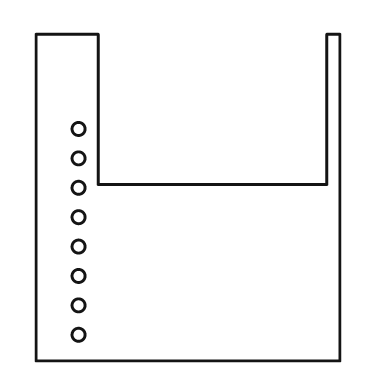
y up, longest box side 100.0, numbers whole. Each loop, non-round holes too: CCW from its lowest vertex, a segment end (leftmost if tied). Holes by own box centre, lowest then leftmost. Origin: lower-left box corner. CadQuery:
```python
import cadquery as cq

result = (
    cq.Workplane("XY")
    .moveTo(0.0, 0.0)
    .lineTo(93.0, 0.0)
    .lineTo(93.0, 100.0)
    .lineTo(89.0, 100.0)
    .lineTo(89.0, 54.0)
    .lineTo(19.0, 54.0)
    .lineTo(19.0, 100.0)
    .lineTo(0.0, 100.0)
    .close()
    .moveTo(13.0, 8.0)
    .circle(2.0)
    .moveTo(13.0, 17.0)
    .circle(2.0)
    .moveTo(13.0, 26.0)
    .circle(2.0)
    .moveTo(13.0, 35.0)
    .circle(2.0)
    .moveTo(13.0, 44.0)
    .circle(2.0)
    .moveTo(13.0, 53.0)
    .circle(2.0)
    .moveTo(13.0, 62.0)
    .circle(2.0)
    .moveTo(13.0, 71.0)
    .circle(2.0)
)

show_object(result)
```